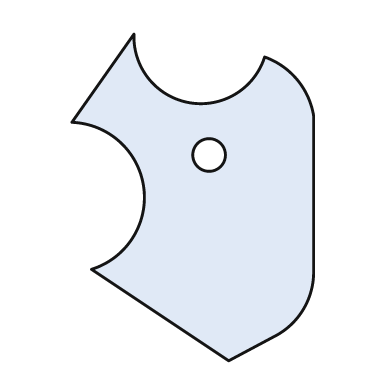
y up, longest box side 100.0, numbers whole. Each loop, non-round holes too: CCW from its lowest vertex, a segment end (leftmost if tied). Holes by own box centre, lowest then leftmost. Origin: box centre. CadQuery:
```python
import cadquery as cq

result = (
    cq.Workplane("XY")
    .moveTo(11.0, -50.0)
    .lineTo(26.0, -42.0)
    .threePointArc((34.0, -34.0), (37.0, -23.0))
    .lineTo(37.0, 25.0)
    .threePointArc((32.0, 36.0), (22.0, 43.0))
    .threePointArc((-1.0, 29.0), (-18.0, 50.0))
    .lineTo(-37.0, 23.0)
    .threePointArc((-15.0, 3.0), (-31.0, -22.0))
    .close()
    .moveTo(5.0, 13.0)
    .circle(5.0)
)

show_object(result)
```